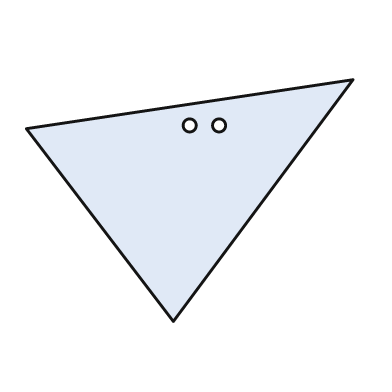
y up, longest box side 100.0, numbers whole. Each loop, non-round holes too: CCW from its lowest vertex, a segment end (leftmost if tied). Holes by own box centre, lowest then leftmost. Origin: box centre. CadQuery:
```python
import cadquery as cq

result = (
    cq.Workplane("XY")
    .moveTo(-5.0, -37.0)
    .lineTo(50.0, 37.0)
    .lineTo(-50.0, 22.0)
    .close()
    .moveTo(0.0, 23.0)
    .circle(2.0)
    .moveTo(9.0, 23.0)
    .circle(2.0)
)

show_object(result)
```